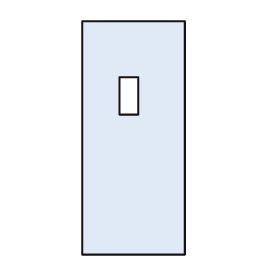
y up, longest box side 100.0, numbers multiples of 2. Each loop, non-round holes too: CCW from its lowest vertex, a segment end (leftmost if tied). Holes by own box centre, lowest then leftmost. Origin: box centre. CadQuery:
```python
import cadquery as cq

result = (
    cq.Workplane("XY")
    .moveTo(-22.0, -50.0)
    .lineTo(22.0, -50.0)
    .lineTo(22.0, 50.0)
    .lineTo(-22.0, 50.0)
    .close()
    .moveTo(-6.0, 10.0)
    .lineTo(2.0, 10.0)
    .lineTo(2.0, 26.0)
    .lineTo(-6.0, 26.0)
    .close()
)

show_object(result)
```